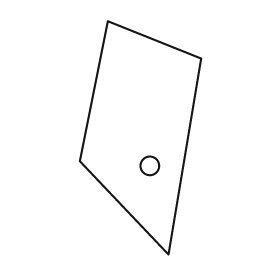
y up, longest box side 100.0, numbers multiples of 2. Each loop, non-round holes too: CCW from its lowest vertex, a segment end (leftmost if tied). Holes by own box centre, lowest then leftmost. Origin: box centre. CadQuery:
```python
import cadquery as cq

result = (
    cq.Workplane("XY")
    .moveTo(12.0, -50.0)
    .lineTo(26.0, 34.0)
    .lineTo(-14.0, 50.0)
    .lineTo(-26.0, -10.0)
    .close()
    .moveTo(4.0, -12.0)
    .circle(4.0)
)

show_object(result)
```